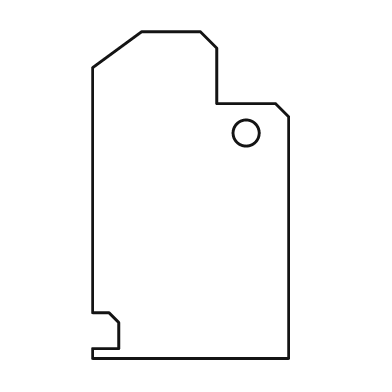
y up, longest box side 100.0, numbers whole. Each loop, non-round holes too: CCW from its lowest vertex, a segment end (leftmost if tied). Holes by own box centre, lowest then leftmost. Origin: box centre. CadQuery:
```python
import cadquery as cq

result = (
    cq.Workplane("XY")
    .moveTo(-30.0, -50.0)
    .lineTo(30.0, -50.0)
    .lineTo(30.0, 24.0)
    .lineTo(26.0, 28.0)
    .lineTo(8.0, 28.0)
    .lineTo(8.0, 45.0)
    .lineTo(3.0, 50.0)
    .lineTo(-15.0, 50.0)
    .lineTo(-30.0, 39.0)
    .lineTo(-30.0, -36.0)
    .lineTo(-25.0, -36.0)
    .lineTo(-22.0, -39.0)
    .lineTo(-22.0, -47.0)
    .lineTo(-30.0, -47.0)
    .close()
    .moveTo(17.0, 19.0)
    .circle(4.0)
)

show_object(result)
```